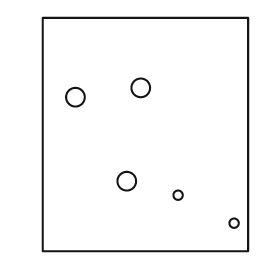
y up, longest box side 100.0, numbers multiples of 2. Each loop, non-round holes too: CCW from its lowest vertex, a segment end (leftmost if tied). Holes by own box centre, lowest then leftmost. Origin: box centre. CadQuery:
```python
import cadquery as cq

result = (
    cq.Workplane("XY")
    .moveTo(-44.0, -50.0)
    .lineTo(44.0, -50.0)
    .lineTo(44.0, 50.0)
    .lineTo(-44.0, 50.0)
    .close()
    .moveTo(38.0, -38.0)
    .circle(2.0)
    .moveTo(14.0, -26.0)
    .circle(2.0)
    .moveTo(-8.0, -20.0)
    .circle(4.0)
    .moveTo(-30.0, 16.0)
    .circle(4.0)
    .moveTo(-2.0, 20.0)
    .circle(4.0)
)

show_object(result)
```